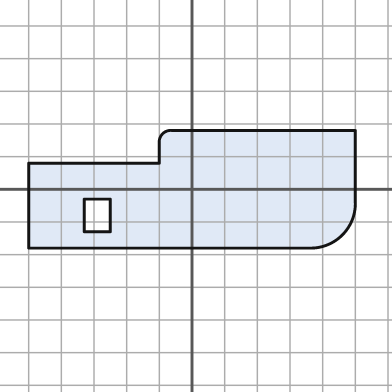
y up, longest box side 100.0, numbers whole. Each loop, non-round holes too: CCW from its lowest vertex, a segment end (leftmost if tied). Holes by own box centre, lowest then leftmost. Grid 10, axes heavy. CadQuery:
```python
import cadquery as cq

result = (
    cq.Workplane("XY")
    .moveTo(-50.0, -18.0)
    .lineTo(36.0, -18.0)
    .threePointArc((46.0, -14.0), (50.0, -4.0))
    .lineTo(50.0, 18.0)
    .lineTo(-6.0, 18.0)
    .threePointArc((-9.0, 17.0), (-10.0, 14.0))
    .lineTo(-10.0, 8.0)
    .lineTo(-50.0, 8.0)
    .close()
    .moveTo(-33.0, -13.0)
    .lineTo(-25.0, -13.0)
    .lineTo(-25.0, -3.0)
    .lineTo(-33.0, -3.0)
    .close()
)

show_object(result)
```